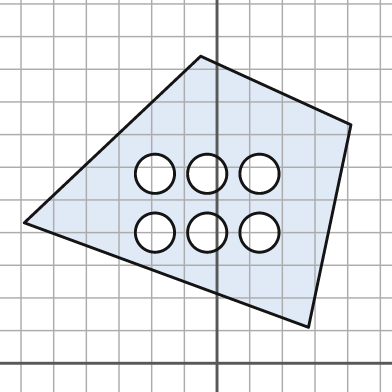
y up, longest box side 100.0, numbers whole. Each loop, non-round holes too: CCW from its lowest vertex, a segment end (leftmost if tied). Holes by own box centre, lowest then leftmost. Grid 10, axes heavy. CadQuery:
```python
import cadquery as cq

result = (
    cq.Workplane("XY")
    .moveTo(28.0, 11.0)
    .lineTo(41.0, 73.0)
    .lineTo(-5.0, 94.0)
    .lineTo(-59.0, 43.0)
    .close()
    .moveTo(-19.0, 40.0)
    .circle(6.0)
    .moveTo(-3.0, 40.0)
    .circle(6.0)
    .moveTo(13.0, 40.0)
    .circle(6.0)
    .moveTo(-19.0, 58.0)
    .circle(6.0)
    .moveTo(-3.0, 58.0)
    .circle(6.0)
    .moveTo(13.0, 58.0)
    .circle(6.0)
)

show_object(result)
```